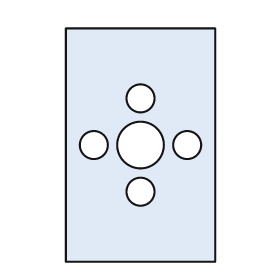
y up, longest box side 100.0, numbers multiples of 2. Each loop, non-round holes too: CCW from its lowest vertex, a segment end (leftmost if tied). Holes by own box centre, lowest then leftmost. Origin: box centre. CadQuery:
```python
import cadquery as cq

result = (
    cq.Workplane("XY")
    .moveTo(-32.0, -50.0)
    .lineTo(32.0, -50.0)
    .lineTo(32.0, 50.0)
    .lineTo(-32.0, 50.0)
    .close()
    .moveTo(0.0, -20.0)
    .circle(6.0)
    .moveTo(-20.0, 0.0)
    .circle(6.0)
    .moveTo(0.0, 0.0)
    .circle(10.0)
    .moveTo(20.0, 0.0)
    .circle(6.0)
    .moveTo(0.0, 20.0)
    .circle(6.0)
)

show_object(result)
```